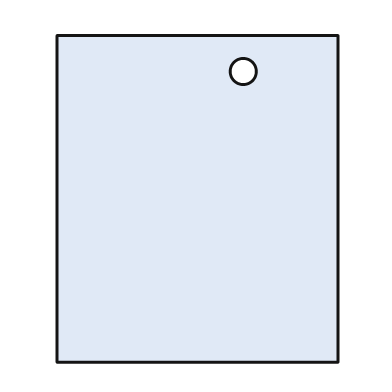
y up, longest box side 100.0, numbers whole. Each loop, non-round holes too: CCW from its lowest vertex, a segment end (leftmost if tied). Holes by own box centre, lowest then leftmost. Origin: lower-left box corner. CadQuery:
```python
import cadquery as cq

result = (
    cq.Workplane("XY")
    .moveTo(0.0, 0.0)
    .lineTo(86.0, 0.0)
    .lineTo(86.0, 100.0)
    .lineTo(0.0, 100.0)
    .close()
    .moveTo(57.0, 89.0)
    .circle(4.0)
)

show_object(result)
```